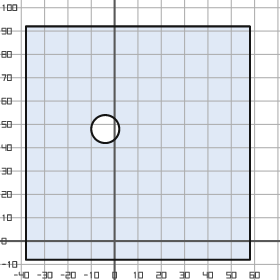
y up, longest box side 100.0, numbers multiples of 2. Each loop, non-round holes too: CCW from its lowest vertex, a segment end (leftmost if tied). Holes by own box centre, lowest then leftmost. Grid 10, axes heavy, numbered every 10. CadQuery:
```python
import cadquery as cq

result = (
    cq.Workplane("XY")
    .moveTo(-38.0, -8.0)
    .lineTo(58.0, -8.0)
    .lineTo(58.0, 92.0)
    .lineTo(-38.0, 92.0)
    .close()
    .moveTo(-4.0, 48.0)
    .circle(6.0)
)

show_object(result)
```